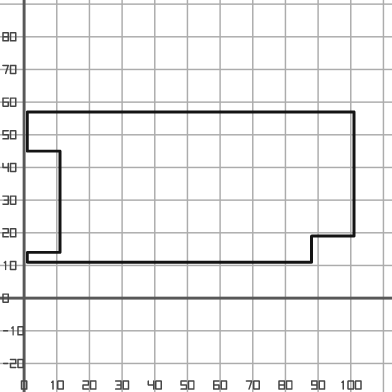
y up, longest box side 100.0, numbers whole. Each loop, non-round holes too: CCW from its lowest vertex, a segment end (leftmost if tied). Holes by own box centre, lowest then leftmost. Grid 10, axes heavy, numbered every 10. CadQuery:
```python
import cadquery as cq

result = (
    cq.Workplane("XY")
    .moveTo(1.0, 11.0)
    .lineTo(88.0, 11.0)
    .lineTo(88.0, 19.0)
    .lineTo(101.0, 19.0)
    .lineTo(101.0, 57.0)
    .lineTo(1.0, 57.0)
    .lineTo(1.0, 45.0)
    .lineTo(11.0, 45.0)
    .lineTo(11.0, 14.0)
    .lineTo(1.0, 14.0)
    .close()
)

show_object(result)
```